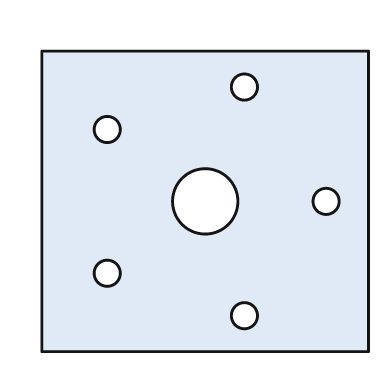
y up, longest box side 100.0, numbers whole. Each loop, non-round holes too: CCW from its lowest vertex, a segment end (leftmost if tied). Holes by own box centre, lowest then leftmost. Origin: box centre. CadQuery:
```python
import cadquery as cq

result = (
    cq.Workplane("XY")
    .moveTo(-50.0, -46.0)
    .lineTo(50.0, -46.0)
    .lineTo(50.0, 46.0)
    .lineTo(-50.0, 46.0)
    .close()
    .moveTo(12.0, -35.0)
    .circle(4.0)
    .moveTo(-30.0, -22.0)
    .circle(4.0)
    .moveTo(0.0, 0.0)
    .circle(10.0)
    .moveTo(37.0, 0.0)
    .circle(4.0)
    .moveTo(-30.0, 22.0)
    .circle(4.0)
    .moveTo(12.0, 35.0)
    .circle(4.0)
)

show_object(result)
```